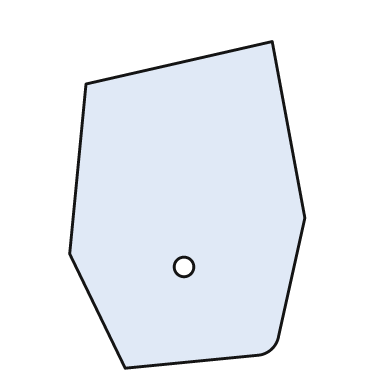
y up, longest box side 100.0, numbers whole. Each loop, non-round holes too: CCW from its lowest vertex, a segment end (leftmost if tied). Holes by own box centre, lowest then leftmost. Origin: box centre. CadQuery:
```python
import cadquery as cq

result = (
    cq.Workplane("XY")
    .moveTo(-19.0, -50.0)
    .lineTo(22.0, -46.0)
    .threePointArc((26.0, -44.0), (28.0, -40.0))
    .lineTo(36.0, -4.0)
    .lineTo(26.0, 50.0)
    .lineTo(-31.0, 37.0)
    .lineTo(-36.0, -15.0)
    .close()
    .moveTo(-1.0, -19.0)
    .circle(3.0)
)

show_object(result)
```